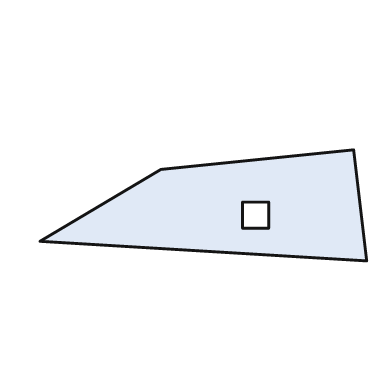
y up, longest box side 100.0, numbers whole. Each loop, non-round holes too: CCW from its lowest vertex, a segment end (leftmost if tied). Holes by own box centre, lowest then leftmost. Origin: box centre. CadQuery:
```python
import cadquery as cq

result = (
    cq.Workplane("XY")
    .moveTo(50.0, -17.0)
    .lineTo(46.0, 17.0)
    .lineTo(-13.0, 11.0)
    .lineTo(-50.0, -11.0)
    .close()
    .moveTo(12.0, -7.0)
    .lineTo(20.0, -7.0)
    .lineTo(20.0, 1.0)
    .lineTo(12.0, 1.0)
    .close()
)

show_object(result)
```